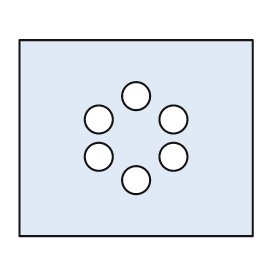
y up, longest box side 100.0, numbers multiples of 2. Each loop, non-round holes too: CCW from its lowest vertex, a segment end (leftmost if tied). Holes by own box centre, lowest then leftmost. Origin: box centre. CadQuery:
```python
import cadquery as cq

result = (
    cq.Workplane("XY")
    .moveTo(-50.0, -42.0)
    .lineTo(50.0, -42.0)
    .lineTo(50.0, 42.0)
    .lineTo(-50.0, 42.0)
    .close()
    .moveTo(0.0, -18.0)
    .circle(6.0)
    .moveTo(-16.0, -8.0)
    .circle(6.0)
    .moveTo(16.0, -8.0)
    .circle(6.0)
    .moveTo(-16.0, 8.0)
    .circle(6.0)
    .moveTo(16.0, 8.0)
    .circle(6.0)
    .moveTo(0.0, 18.0)
    .circle(6.0)
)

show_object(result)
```